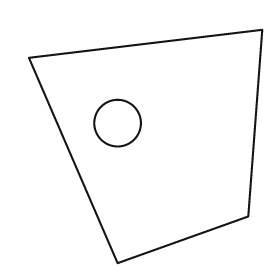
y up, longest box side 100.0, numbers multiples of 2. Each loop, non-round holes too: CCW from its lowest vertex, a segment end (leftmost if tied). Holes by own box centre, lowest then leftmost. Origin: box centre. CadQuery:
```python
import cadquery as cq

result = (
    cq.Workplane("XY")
    .moveTo(-12.0, -50.0)
    .lineTo(44.0, -30.0)
    .lineTo(50.0, 50.0)
    .lineTo(-50.0, 38.0)
    .close()
    .moveTo(-12.0, 10.0)
    .circle(10.0)
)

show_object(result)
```